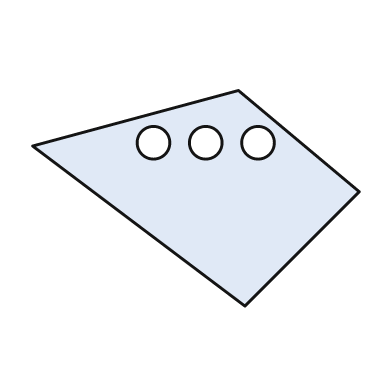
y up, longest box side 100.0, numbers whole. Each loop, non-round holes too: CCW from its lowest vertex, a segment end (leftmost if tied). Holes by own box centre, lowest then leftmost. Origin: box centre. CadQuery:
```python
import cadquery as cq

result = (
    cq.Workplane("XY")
    .moveTo(15.0, -33.0)
    .lineTo(50.0, 2.0)
    .lineTo(13.0, 33.0)
    .lineTo(-50.0, 16.0)
    .close()
    .moveTo(-13.0, 17.0)
    .circle(5.0)
    .moveTo(3.0, 17.0)
    .circle(5.0)
    .moveTo(19.0, 17.0)
    .circle(5.0)
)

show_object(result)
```